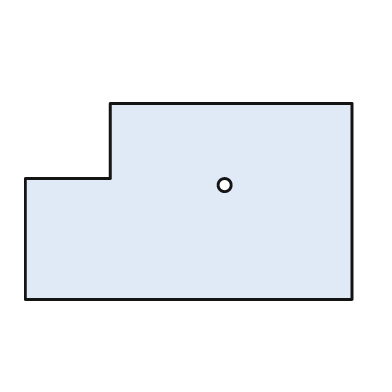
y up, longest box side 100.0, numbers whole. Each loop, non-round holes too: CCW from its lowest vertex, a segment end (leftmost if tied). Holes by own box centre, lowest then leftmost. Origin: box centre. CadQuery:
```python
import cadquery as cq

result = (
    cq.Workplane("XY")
    .moveTo(-50.0, -30.0)
    .lineTo(50.0, -30.0)
    .lineTo(50.0, 30.0)
    .lineTo(-24.0, 30.0)
    .lineTo(-24.0, 7.0)
    .lineTo(-50.0, 7.0)
    .close()
    .moveTo(11.0, 5.0)
    .circle(2.0)
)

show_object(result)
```